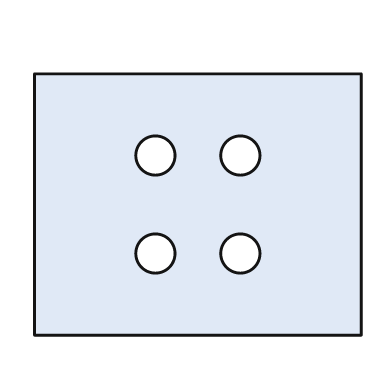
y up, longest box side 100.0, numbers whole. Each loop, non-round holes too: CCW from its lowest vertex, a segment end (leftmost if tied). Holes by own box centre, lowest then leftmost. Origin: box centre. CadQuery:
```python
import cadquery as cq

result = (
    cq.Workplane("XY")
    .moveTo(-50.0, -40.0)
    .lineTo(50.0, -40.0)
    .lineTo(50.0, 40.0)
    .lineTo(-50.0, 40.0)
    .close()
    .moveTo(-13.0, -15.0)
    .circle(6.0)
    .moveTo(13.0, -15.0)
    .circle(6.0)
    .moveTo(-13.0, 15.0)
    .circle(6.0)
    .moveTo(13.0, 15.0)
    .circle(6.0)
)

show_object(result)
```